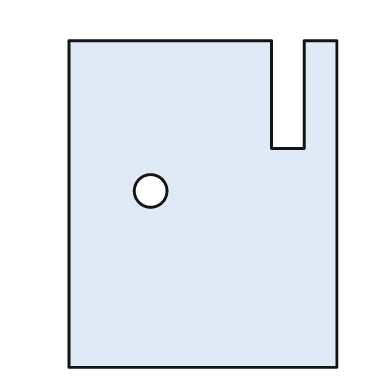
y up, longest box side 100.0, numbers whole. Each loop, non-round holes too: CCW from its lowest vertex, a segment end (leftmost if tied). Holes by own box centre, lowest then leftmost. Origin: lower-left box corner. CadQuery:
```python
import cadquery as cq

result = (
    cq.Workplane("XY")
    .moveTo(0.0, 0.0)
    .lineTo(82.0, 0.0)
    .lineTo(82.0, 100.0)
    .lineTo(72.0, 100.0)
    .lineTo(72.0, 67.0)
    .lineTo(62.0, 67.0)
    .lineTo(62.0, 100.0)
    .lineTo(0.0, 100.0)
    .close()
    .moveTo(25.0, 54.0)
    .circle(5.0)
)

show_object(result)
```